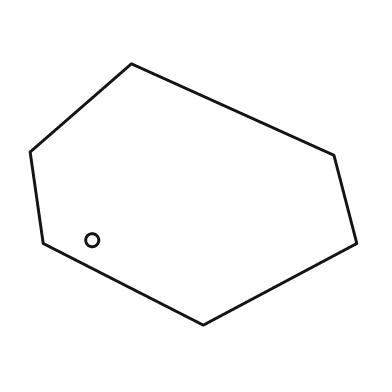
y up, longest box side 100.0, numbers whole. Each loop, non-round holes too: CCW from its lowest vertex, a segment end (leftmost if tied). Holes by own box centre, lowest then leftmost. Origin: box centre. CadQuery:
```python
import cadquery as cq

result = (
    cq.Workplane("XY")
    .moveTo(3.0, -40.0)
    .lineTo(50.0, -15.0)
    .lineTo(43.0, 12.0)
    .lineTo(-19.0, 40.0)
    .lineTo(-50.0, 13.0)
    .lineTo(-46.0, -15.0)
    .close()
    .moveTo(-31.0, -14.0)
    .circle(2.0)
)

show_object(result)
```